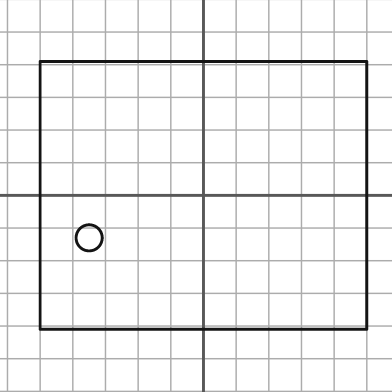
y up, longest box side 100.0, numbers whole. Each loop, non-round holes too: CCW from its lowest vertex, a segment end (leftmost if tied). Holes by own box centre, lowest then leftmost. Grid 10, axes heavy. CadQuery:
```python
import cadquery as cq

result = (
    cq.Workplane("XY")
    .moveTo(-50.0, -41.0)
    .lineTo(50.0, -41.0)
    .lineTo(50.0, 41.0)
    .lineTo(-50.0, 41.0)
    .close()
    .moveTo(-35.0, -13.0)
    .circle(4.0)
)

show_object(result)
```